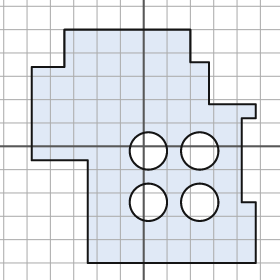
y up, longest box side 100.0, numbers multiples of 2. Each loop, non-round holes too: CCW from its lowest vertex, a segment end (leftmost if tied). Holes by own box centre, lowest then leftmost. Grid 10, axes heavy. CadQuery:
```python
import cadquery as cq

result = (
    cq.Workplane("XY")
    .moveTo(-24.0, -50.0)
    .lineTo(48.0, -50.0)
    .lineTo(48.0, -24.0)
    .lineTo(42.0, -24.0)
    .lineTo(42.0, 12.0)
    .lineTo(48.0, 12.0)
    .lineTo(48.0, 18.0)
    .lineTo(28.0, 18.0)
    .lineTo(28.0, 36.0)
    .lineTo(20.0, 36.0)
    .lineTo(20.0, 50.0)
    .lineTo(-34.0, 50.0)
    .lineTo(-34.0, 34.0)
    .lineTo(-48.0, 34.0)
    .lineTo(-48.0, -6.0)
    .lineTo(-24.0, -6.0)
    .close()
    .moveTo(2.0, -24.0)
    .circle(8.0)
    .moveTo(24.0, -24.0)
    .circle(8.0)
    .moveTo(2.0, -2.0)
    .circle(8.0)
    .moveTo(24.0, -2.0)
    .circle(8.0)
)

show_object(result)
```